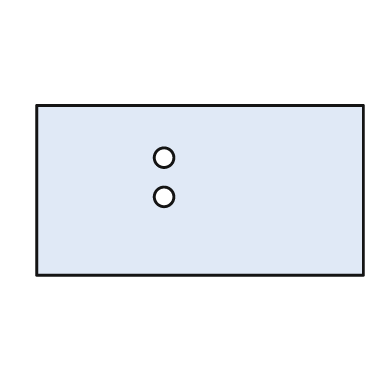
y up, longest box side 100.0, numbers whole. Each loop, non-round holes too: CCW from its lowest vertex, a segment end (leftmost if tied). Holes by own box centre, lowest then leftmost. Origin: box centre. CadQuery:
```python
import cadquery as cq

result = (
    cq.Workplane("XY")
    .moveTo(-50.0, -26.0)
    .lineTo(50.0, -26.0)
    .lineTo(50.0, 26.0)
    .lineTo(-50.0, 26.0)
    .close()
    .moveTo(-11.0, -2.0)
    .circle(3.0)
    .moveTo(-11.0, 10.0)
    .circle(3.0)
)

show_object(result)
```